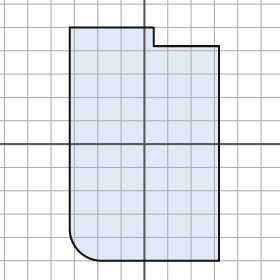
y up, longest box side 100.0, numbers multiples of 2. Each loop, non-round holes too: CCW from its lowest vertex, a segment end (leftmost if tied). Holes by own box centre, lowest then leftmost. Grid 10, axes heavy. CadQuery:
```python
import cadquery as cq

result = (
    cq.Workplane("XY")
    .moveTo(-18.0, -50.0)
    .lineTo(32.0, -50.0)
    .lineTo(32.0, 42.0)
    .lineTo(4.0, 42.0)
    .lineTo(4.0, 50.0)
    .lineTo(-32.0, 50.0)
    .lineTo(-32.0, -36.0)
    .threePointArc((-28.0, -46.0), (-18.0, -50.0))
    .close()
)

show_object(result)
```